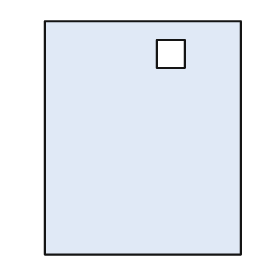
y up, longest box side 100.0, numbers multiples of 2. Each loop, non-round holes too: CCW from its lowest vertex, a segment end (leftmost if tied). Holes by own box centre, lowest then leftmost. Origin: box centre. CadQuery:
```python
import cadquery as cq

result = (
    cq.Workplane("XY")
    .moveTo(-42.0, -50.0)
    .lineTo(42.0, -50.0)
    .lineTo(42.0, 50.0)
    .lineTo(-42.0, 50.0)
    .close()
    .moveTo(6.0, 30.0)
    .lineTo(18.0, 30.0)
    .lineTo(18.0, 42.0)
    .lineTo(6.0, 42.0)
    .close()
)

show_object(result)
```